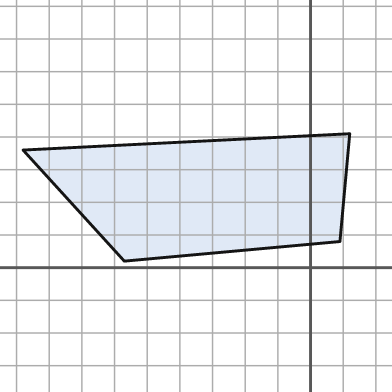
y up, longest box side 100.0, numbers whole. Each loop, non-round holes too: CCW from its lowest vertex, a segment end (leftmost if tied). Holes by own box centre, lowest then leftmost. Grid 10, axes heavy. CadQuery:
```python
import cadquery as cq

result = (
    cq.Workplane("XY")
    .moveTo(-57.0, 2.0)
    .lineTo(9.0, 8.0)
    .lineTo(12.0, 41.0)
    .lineTo(-88.0, 36.0)
    .close()
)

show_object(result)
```